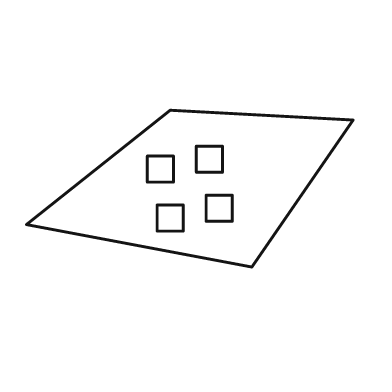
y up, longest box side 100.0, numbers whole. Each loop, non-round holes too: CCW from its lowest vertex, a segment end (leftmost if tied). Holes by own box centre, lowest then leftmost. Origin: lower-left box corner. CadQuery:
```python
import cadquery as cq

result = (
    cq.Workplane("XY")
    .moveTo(69.0, 0.0)
    .lineTo(100.0, 45.0)
    .lineTo(44.0, 48.0)
    .lineTo(0.0, 13.0)
    .close()
    .moveTo(40.0, 11.0)
    .lineTo(48.0, 11.0)
    .lineTo(48.0, 19.0)
    .lineTo(40.0, 19.0)
    .close()
    .moveTo(55.0, 14.0)
    .lineTo(63.0, 14.0)
    .lineTo(63.0, 22.0)
    .lineTo(55.0, 22.0)
    .close()
    .moveTo(37.0, 26.0)
    .lineTo(45.0, 26.0)
    .lineTo(45.0, 34.0)
    .lineTo(37.0, 34.0)
    .close()
    .moveTo(52.0, 29.0)
    .lineTo(60.0, 29.0)
    .lineTo(60.0, 37.0)
    .lineTo(52.0, 37.0)
    .close()
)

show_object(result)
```